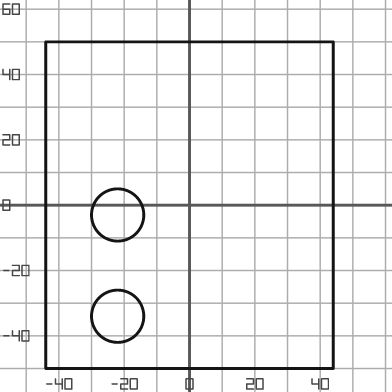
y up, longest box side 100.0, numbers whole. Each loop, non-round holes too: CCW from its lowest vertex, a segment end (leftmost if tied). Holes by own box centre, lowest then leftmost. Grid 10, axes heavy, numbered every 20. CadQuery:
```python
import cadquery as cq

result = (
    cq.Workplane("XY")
    .moveTo(-44.0, -50.0)
    .lineTo(44.0, -50.0)
    .lineTo(44.0, 50.0)
    .lineTo(-44.0, 50.0)
    .close()
    .moveTo(-22.0, -34.0)
    .circle(8.0)
    .moveTo(-22.0, -3.0)
    .circle(8.0)
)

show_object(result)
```